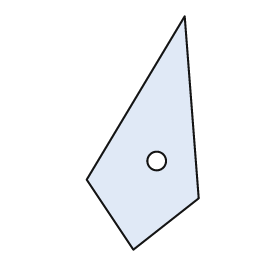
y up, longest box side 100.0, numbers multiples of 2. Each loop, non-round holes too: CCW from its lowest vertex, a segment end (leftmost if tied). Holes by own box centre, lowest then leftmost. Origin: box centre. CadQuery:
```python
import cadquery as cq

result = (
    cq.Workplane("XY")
    .moveTo(-4.0, -50.0)
    .lineTo(24.0, -28.0)
    .lineTo(18.0, 50.0)
    .lineTo(-24.0, -20.0)
    .close()
    .moveTo(6.0, -12.0)
    .circle(4.0)
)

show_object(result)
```